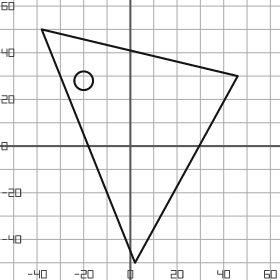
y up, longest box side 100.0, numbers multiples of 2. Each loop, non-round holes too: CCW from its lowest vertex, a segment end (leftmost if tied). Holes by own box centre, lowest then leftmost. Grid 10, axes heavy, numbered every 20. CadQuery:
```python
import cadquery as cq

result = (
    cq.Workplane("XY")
    .moveTo(2.0, -50.0)
    .lineTo(46.0, 30.0)
    .lineTo(-38.0, 50.0)
    .close()
    .moveTo(-20.0, 28.0)
    .circle(4.0)
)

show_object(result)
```